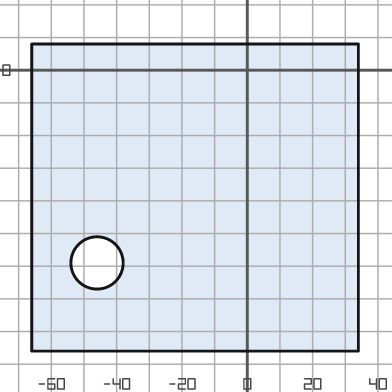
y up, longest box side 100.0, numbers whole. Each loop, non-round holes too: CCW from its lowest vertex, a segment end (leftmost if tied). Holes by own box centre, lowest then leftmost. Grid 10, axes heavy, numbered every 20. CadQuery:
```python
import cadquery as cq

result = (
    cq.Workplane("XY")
    .moveTo(-66.0, -86.0)
    .lineTo(34.0, -86.0)
    .lineTo(34.0, 8.0)
    .lineTo(-66.0, 8.0)
    .close()
    .moveTo(-46.0, -59.0)
    .circle(8.0)
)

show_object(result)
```